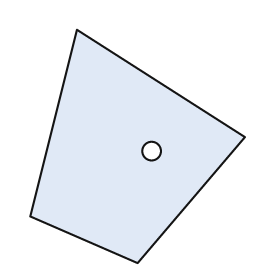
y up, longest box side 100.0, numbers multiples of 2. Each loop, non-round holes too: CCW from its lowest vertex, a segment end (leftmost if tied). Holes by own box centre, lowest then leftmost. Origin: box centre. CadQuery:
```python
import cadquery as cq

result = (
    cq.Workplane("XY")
    .moveTo(0.0, -50.0)
    .lineTo(46.0, 4.0)
    .lineTo(-26.0, 50.0)
    .lineTo(-46.0, -30.0)
    .close()
    .moveTo(6.0, -2.0)
    .circle(4.0)
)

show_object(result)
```